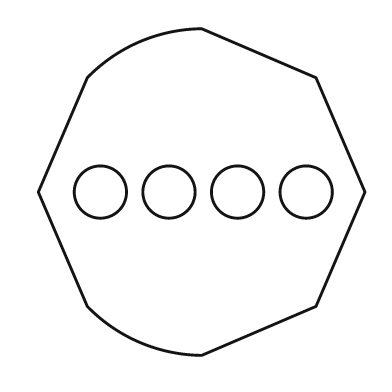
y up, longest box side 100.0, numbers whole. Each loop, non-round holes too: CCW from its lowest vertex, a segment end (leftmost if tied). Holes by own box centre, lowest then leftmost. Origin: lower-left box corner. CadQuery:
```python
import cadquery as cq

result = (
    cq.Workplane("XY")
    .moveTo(50.0, 0.0)
    .lineTo(85.0, 15.0)
    .lineTo(100.0, 50.0)
    .lineTo(85.0, 85.0)
    .lineTo(50.0, 100.0)
    .threePointArc((31.0, 96.0), (15.0, 85.0))
    .lineTo(0.0, 50.0)
    .lineTo(15.0, 15.0)
    .threePointArc((31.0, 4.0), (50.0, 0.0))
    .close()
    .moveTo(19.0, 50.0)
    .circle(8.0)
    .moveTo(40.0, 50.0)
    .circle(8.0)
    .moveTo(61.0, 50.0)
    .circle(8.0)
    .moveTo(82.0, 50.0)
    .circle(8.0)
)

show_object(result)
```